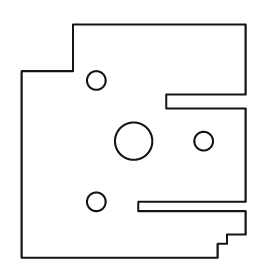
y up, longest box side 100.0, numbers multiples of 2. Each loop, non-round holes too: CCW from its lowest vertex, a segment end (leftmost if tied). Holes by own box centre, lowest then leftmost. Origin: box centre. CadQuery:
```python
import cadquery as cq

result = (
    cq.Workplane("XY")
    .moveTo(-48.0, -50.0)
    .lineTo(36.0, -50.0)
    .lineTo(36.0, -44.0)
    .lineTo(40.0, -44.0)
    .lineTo(40.0, -40.0)
    .lineTo(48.0, -40.0)
    .lineTo(48.0, -30.0)
    .lineTo(2.0, -30.0)
    .lineTo(2.0, -26.0)
    .lineTo(48.0, -26.0)
    .lineTo(48.0, 14.0)
    .lineTo(14.0, 14.0)
    .lineTo(14.0, 20.0)
    .lineTo(48.0, 20.0)
    .lineTo(48.0, 50.0)
    .lineTo(-26.0, 50.0)
    .lineTo(-26.0, 30.0)
    .lineTo(-48.0, 30.0)
    .close()
    .moveTo(-16.0, -26.0)
    .circle(4.0)
    .moveTo(0.0, 0.0)
    .circle(8.0)
    .moveTo(30.0, 0.0)
    .circle(4.0)
    .moveTo(-16.0, 26.0)
    .circle(4.0)
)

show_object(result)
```